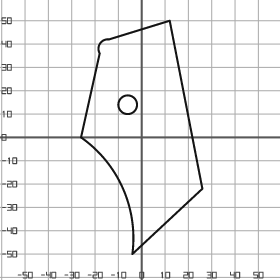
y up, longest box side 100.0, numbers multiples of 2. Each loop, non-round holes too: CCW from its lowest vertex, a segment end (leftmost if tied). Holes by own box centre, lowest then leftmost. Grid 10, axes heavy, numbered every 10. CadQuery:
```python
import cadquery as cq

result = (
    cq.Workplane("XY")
    .moveTo(-4.0, -50.0)
    .lineTo(26.0, -22.0)
    .lineTo(12.0, 50.0)
    .lineTo(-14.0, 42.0)
    .threePointArc((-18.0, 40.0), (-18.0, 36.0))
    .lineTo(-26.0, 0.0)
    .threePointArc((-8.0, -22.0), (-4.0, -50.0))
    .close()
    .moveTo(-6.0, 14.0)
    .circle(4.0)
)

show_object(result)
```